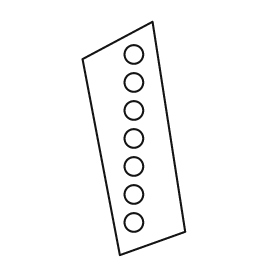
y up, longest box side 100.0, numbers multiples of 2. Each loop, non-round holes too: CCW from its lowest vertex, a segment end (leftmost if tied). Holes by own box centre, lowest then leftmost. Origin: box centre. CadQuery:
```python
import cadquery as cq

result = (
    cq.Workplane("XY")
    .moveTo(-6.0, -50.0)
    .lineTo(22.0, -40.0)
    .lineTo(8.0, 50.0)
    .lineTo(-22.0, 34.0)
    .close()
    .moveTo(0.0, -36.0)
    .circle(4.0)
    .moveTo(0.0, -24.0)
    .circle(4.0)
    .moveTo(0.0, -12.0)
    .circle(4.0)
    .moveTo(0.0, 0.0)
    .circle(4.0)
    .moveTo(0.0, 12.0)
    .circle(4.0)
    .moveTo(0.0, 24.0)
    .circle(4.0)
    .moveTo(0.0, 36.0)
    .circle(4.0)
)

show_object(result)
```